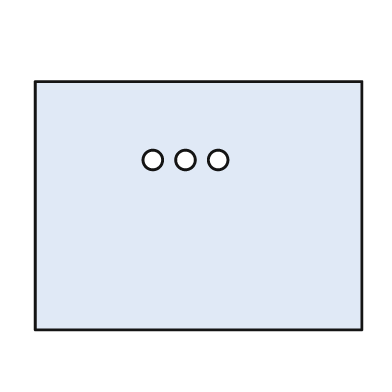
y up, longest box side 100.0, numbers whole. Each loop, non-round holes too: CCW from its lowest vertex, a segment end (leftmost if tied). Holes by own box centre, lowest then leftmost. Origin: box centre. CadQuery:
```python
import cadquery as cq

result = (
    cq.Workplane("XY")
    .moveTo(-50.0, -38.0)
    .lineTo(50.0, -38.0)
    .lineTo(50.0, 38.0)
    .lineTo(-50.0, 38.0)
    .close()
    .moveTo(-14.0, 14.0)
    .circle(3.0)
    .moveTo(-4.0, 14.0)
    .circle(3.0)
    .moveTo(6.0, 14.0)
    .circle(3.0)
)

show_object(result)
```